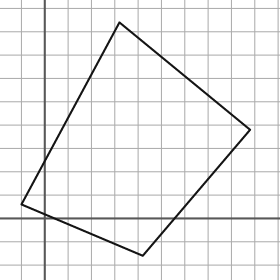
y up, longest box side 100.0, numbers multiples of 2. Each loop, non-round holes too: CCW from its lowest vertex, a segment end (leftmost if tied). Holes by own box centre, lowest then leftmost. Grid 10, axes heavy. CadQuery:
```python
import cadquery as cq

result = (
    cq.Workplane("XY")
    .moveTo(42.0, -16.0)
    .lineTo(88.0, 38.0)
    .lineTo(32.0, 84.0)
    .lineTo(-10.0, 6.0)
    .close()
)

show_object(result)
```